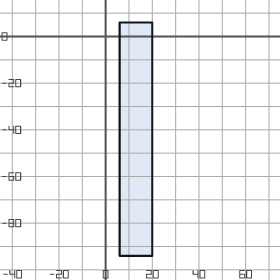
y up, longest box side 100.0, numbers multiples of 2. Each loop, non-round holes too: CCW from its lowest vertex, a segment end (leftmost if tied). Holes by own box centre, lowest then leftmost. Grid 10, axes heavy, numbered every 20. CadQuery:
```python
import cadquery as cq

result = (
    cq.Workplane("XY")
    .moveTo(6.0, -94.0)
    .lineTo(20.0, -94.0)
    .lineTo(20.0, 6.0)
    .lineTo(6.0, 6.0)
    .close()
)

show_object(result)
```